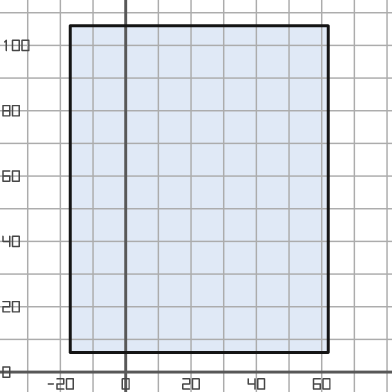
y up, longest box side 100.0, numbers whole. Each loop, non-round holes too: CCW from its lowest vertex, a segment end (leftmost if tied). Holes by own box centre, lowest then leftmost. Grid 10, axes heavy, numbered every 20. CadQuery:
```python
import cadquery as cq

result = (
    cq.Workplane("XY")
    .moveTo(-17.0, 6.0)
    .lineTo(62.0, 6.0)
    .lineTo(62.0, 106.0)
    .lineTo(-17.0, 106.0)
    .close()
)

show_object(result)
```